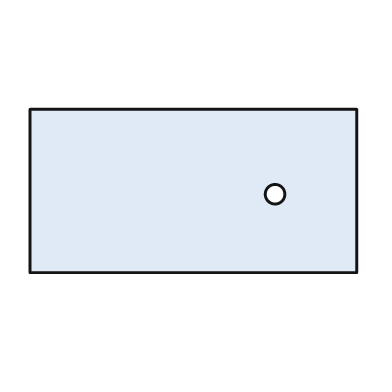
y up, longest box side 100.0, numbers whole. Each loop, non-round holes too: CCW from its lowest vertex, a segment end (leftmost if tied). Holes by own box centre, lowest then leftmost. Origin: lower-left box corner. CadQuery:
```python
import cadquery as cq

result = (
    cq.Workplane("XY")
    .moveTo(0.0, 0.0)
    .lineTo(100.0, 0.0)
    .lineTo(100.0, 50.0)
    .lineTo(0.0, 50.0)
    .close()
    .moveTo(75.0, 24.0)
    .circle(3.0)
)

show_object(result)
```